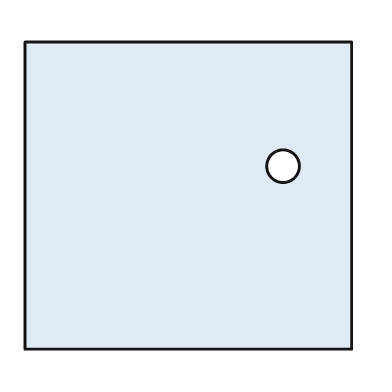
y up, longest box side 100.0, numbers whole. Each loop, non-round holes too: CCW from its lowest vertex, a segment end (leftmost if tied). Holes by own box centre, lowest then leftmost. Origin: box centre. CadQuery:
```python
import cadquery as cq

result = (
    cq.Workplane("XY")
    .moveTo(-50.0, -47.0)
    .lineTo(50.0, -47.0)
    .lineTo(50.0, 47.0)
    .lineTo(-50.0, 47.0)
    .close()
    .moveTo(29.0, 9.0)
    .circle(5.0)
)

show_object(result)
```